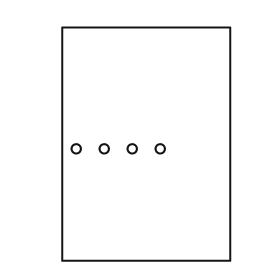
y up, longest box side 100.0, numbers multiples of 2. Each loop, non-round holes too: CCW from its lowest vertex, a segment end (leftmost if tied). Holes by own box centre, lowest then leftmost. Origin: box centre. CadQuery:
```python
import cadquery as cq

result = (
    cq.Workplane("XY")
    .moveTo(-36.0, -50.0)
    .lineTo(36.0, -50.0)
    .lineTo(36.0, 50.0)
    .lineTo(-36.0, 50.0)
    .close()
    .moveTo(-30.0, -2.0)
    .circle(2.0)
    .moveTo(-18.0, -2.0)
    .circle(2.0)
    .moveTo(-6.0, -2.0)
    .circle(2.0)
    .moveTo(6.0, -2.0)
    .circle(2.0)
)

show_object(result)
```